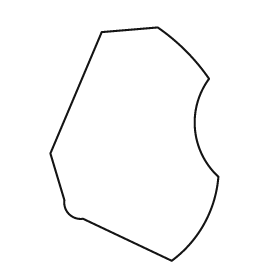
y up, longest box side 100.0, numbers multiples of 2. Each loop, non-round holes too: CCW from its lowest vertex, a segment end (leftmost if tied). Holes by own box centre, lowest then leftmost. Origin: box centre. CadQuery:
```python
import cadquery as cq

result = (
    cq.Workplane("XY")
    .moveTo(16.0, -50.0)
    .threePointArc((30.0, -34.0), (36.0, -14.0))
    .threePointArc((26.0, 6.0), (32.0, 28.0))
    .threePointArc((22.0, 40.0), (10.0, 50.0))
    .lineTo(-14.0, 48.0)
    .lineTo(-36.0, -4.0)
    .lineTo(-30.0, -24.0)
    .threePointArc((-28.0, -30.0), (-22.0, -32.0))
    .close()
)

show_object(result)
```